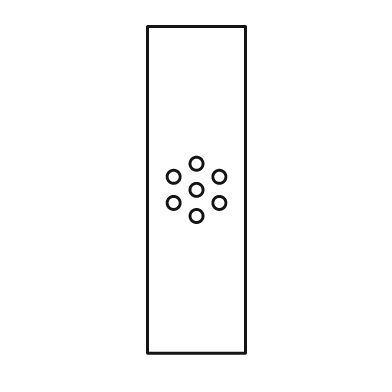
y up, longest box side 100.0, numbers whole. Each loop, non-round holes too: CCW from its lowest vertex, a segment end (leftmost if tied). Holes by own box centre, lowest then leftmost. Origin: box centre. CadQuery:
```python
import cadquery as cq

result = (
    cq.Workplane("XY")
    .moveTo(-15.0, -50.0)
    .lineTo(15.0, -50.0)
    .lineTo(15.0, 50.0)
    .lineTo(-15.0, 50.0)
    .close()
    .moveTo(0.0, -8.0)
    .circle(2.0)
    .moveTo(-7.0, -4.0)
    .circle(2.0)
    .moveTo(7.0, -4.0)
    .circle(2.0)
    .moveTo(0.0, 0.0)
    .circle(2.0)
    .moveTo(-7.0, 4.0)
    .circle(2.0)
    .moveTo(7.0, 4.0)
    .circle(2.0)
    .moveTo(0.0, 8.0)
    .circle(2.0)
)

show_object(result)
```